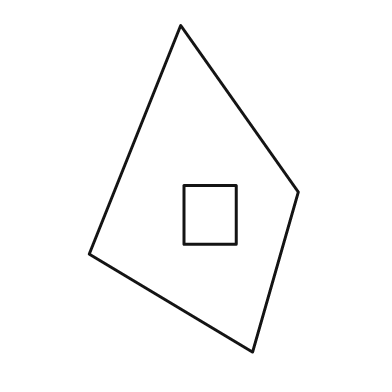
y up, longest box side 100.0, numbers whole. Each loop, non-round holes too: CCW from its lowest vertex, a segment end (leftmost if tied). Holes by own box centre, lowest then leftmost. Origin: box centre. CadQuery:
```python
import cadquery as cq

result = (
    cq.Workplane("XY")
    .moveTo(18.0, -50.0)
    .lineTo(32.0, -1.0)
    .lineTo(-4.0, 50.0)
    .lineTo(-32.0, -20.0)
    .close()
    .moveTo(-3.0, -17.0)
    .lineTo(13.0, -17.0)
    .lineTo(13.0, 1.0)
    .lineTo(-3.0, 1.0)
    .close()
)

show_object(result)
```